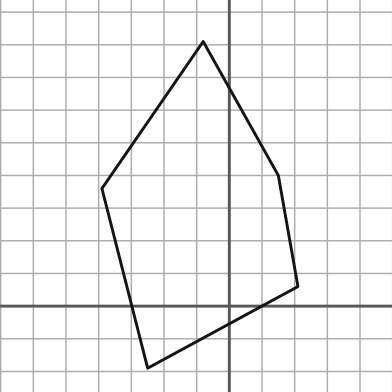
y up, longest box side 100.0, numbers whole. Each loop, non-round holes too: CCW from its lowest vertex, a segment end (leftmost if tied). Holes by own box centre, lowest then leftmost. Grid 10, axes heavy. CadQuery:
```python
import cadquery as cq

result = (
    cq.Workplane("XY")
    .moveTo(-25.0, -19.0)
    .lineTo(21.0, 6.0)
    .lineTo(15.0, 40.0)
    .lineTo(-8.0, 81.0)
    .lineTo(-39.0, 36.0)
    .close()
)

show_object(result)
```